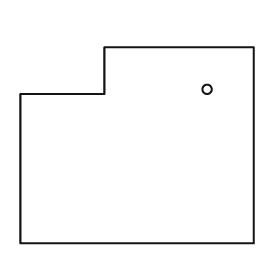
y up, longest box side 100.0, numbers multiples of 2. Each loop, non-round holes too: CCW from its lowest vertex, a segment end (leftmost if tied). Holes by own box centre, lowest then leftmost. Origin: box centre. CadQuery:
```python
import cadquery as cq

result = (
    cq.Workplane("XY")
    .moveTo(-50.0, -42.0)
    .lineTo(50.0, -42.0)
    .lineTo(50.0, 42.0)
    .lineTo(-14.0, 42.0)
    .lineTo(-14.0, 22.0)
    .lineTo(-50.0, 22.0)
    .close()
    .moveTo(30.0, 24.0)
    .circle(2.0)
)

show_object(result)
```